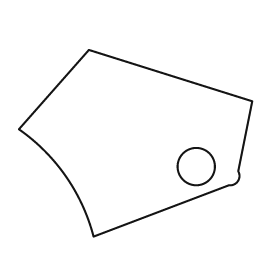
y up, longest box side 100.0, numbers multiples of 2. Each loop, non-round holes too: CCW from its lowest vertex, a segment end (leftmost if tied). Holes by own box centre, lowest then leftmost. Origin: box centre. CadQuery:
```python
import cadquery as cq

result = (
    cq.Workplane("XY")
    .moveTo(-18.0, -40.0)
    .lineTo(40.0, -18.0)
    .threePointArc((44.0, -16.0), (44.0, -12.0))
    .lineTo(50.0, 18.0)
    .lineTo(-20.0, 40.0)
    .lineTo(-50.0, 6.0)
    .threePointArc((-30.0, -14.0), (-18.0, -40.0))
    .close()
    .moveTo(26.0, -10.0)
    .circle(8.0)
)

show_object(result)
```